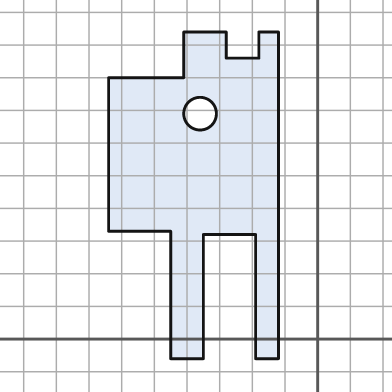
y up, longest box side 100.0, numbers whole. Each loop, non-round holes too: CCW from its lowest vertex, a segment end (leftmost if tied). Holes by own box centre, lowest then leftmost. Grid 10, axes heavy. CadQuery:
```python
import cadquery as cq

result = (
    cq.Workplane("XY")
    .moveTo(-45.0, -6.0)
    .lineTo(-35.0, -6.0)
    .lineTo(-35.0, 32.0)
    .lineTo(-19.0, 32.0)
    .lineTo(-19.0, -6.0)
    .lineTo(-12.0, -6.0)
    .lineTo(-12.0, 94.0)
    .lineTo(-18.0, 94.0)
    .lineTo(-18.0, 86.0)
    .lineTo(-28.0, 86.0)
    .lineTo(-28.0, 94.0)
    .lineTo(-41.0, 94.0)
    .lineTo(-41.0, 80.0)
    .lineTo(-64.0, 80.0)
    .lineTo(-64.0, 33.0)
    .lineTo(-45.0, 33.0)
    .close()
    .moveTo(-36.0, 69.0)
    .circle(5.0)
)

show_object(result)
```